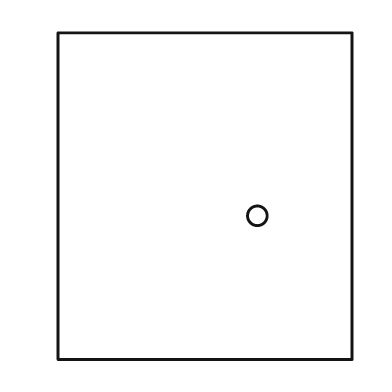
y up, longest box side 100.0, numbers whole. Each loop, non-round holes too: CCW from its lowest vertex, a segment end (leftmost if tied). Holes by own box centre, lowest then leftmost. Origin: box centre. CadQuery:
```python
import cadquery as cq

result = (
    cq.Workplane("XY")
    .moveTo(-45.0, -50.0)
    .lineTo(45.0, -50.0)
    .lineTo(45.0, 50.0)
    .lineTo(-45.0, 50.0)
    .close()
    .moveTo(16.0, -6.0)
    .circle(3.0)
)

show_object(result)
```